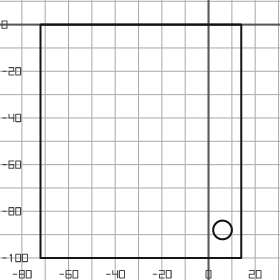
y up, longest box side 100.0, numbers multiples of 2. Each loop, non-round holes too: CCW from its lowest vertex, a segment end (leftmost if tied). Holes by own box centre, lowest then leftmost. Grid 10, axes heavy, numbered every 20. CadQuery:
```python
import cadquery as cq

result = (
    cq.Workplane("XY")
    .moveTo(-72.0, -100.0)
    .lineTo(14.0, -100.0)
    .lineTo(14.0, 0.0)
    .lineTo(-72.0, 0.0)
    .close()
    .moveTo(6.0, -88.0)
    .circle(4.0)
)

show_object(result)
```